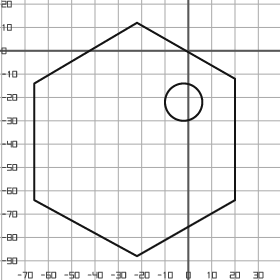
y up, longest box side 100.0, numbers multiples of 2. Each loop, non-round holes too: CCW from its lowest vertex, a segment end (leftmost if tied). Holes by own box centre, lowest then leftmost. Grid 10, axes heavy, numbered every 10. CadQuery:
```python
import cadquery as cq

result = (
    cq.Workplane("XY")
    .moveTo(-22.0, -88.0)
    .lineTo(20.0, -64.0)
    .lineTo(20.0, -12.0)
    .lineTo(-22.0, 12.0)
    .lineTo(-66.0, -14.0)
    .lineTo(-66.0, -64.0)
    .close()
    .moveTo(-2.0, -22.0)
    .circle(8.0)
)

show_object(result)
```